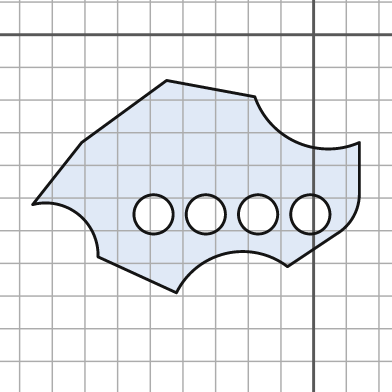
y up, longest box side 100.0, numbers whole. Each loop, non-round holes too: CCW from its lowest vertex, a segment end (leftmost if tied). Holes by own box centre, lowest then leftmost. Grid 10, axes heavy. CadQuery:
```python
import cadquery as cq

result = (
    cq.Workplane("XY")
    .moveTo(-42.0, -79.0)
    .threePointArc((-27.0, -67.0), (-8.0, -71.0))
    .lineTo(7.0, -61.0)
    .threePointArc((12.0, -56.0), (14.0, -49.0))
    .lineTo(14.0, -33.0)
    .threePointArc((-5.0, -33.0), (-18.0, -19.0))
    .lineTo(-45.0, -14.0)
    .lineTo(-71.0, -33.0)
    .lineTo(-86.0, -52.0)
    .threePointArc((-72.0, -55.0), (-66.0, -68.0))
    .close()
    .moveTo(-49.0, -55.0)
    .circle(6.0)
    .moveTo(-33.0, -55.0)
    .circle(6.0)
    .moveTo(-17.0, -55.0)
    .circle(6.0)
    .moveTo(-1.0, -55.0)
    .circle(6.0)
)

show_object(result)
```